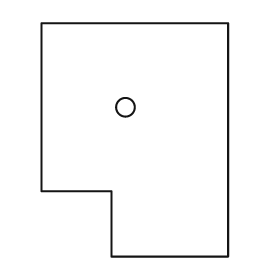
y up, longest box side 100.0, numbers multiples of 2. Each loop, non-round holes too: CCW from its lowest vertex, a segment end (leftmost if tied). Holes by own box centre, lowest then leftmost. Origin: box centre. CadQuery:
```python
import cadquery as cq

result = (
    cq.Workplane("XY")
    .moveTo(-10.0, -50.0)
    .lineTo(40.0, -50.0)
    .lineTo(40.0, 50.0)
    .lineTo(-40.0, 50.0)
    .lineTo(-40.0, -22.0)
    .lineTo(-10.0, -22.0)
    .close()
    .moveTo(-4.0, 14.0)
    .circle(4.0)
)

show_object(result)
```